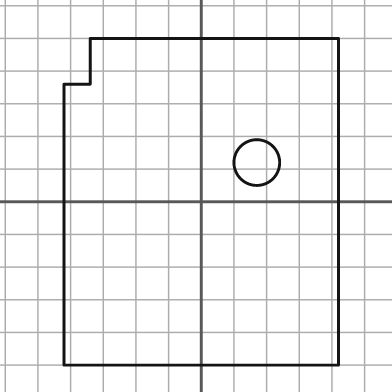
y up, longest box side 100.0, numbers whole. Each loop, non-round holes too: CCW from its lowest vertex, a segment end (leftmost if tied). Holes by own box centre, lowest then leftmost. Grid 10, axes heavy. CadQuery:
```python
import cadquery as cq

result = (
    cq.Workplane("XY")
    .moveTo(-42.0, -50.0)
    .lineTo(42.0, -50.0)
    .lineTo(42.0, 50.0)
    .lineTo(-34.0, 50.0)
    .lineTo(-34.0, 36.0)
    .lineTo(-42.0, 36.0)
    .close()
    .moveTo(17.0, 12.0)
    .circle(7.0)
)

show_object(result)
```